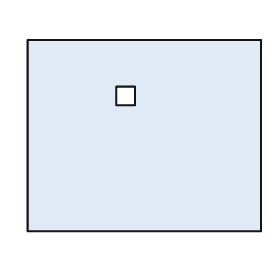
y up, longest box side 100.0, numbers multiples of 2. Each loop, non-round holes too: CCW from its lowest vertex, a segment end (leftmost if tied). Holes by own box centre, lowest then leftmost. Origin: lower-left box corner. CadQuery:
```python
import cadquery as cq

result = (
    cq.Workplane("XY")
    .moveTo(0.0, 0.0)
    .lineTo(100.0, 0.0)
    .lineTo(100.0, 82.0)
    .lineTo(0.0, 82.0)
    .close()
    .moveTo(38.0, 54.0)
    .lineTo(46.0, 54.0)
    .lineTo(46.0, 62.0)
    .lineTo(38.0, 62.0)
    .close()
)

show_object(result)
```